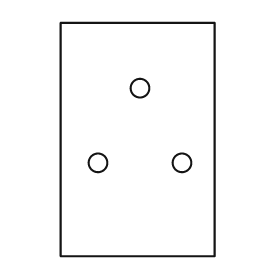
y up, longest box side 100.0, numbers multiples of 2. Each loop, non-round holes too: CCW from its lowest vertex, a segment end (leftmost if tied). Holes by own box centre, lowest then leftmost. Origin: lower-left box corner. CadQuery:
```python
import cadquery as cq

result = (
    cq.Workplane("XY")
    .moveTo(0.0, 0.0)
    .lineTo(66.0, 0.0)
    .lineTo(66.0, 100.0)
    .lineTo(0.0, 100.0)
    .close()
    .moveTo(16.0, 40.0)
    .circle(4.0)
    .moveTo(52.0, 40.0)
    .circle(4.0)
    .moveTo(34.0, 72.0)
    .circle(4.0)
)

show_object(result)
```